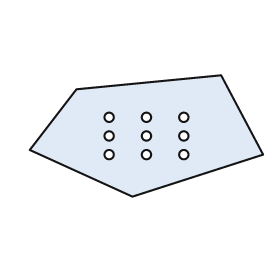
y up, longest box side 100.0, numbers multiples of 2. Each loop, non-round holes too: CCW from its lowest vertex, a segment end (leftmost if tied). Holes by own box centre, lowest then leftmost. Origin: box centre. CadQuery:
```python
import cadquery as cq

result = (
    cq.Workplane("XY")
    .moveTo(-6.0, -26.0)
    .lineTo(50.0, -8.0)
    .lineTo(32.0, 26.0)
    .lineTo(-30.0, 20.0)
    .lineTo(-50.0, -6.0)
    .close()
    .moveTo(-16.0, -8.0)
    .circle(2.0)
    .moveTo(0.0, -8.0)
    .circle(2.0)
    .moveTo(16.0, -8.0)
    .circle(2.0)
    .moveTo(-16.0, 0.0)
    .circle(2.0)
    .moveTo(0.0, 0.0)
    .circle(2.0)
    .moveTo(16.0, 0.0)
    .circle(2.0)
    .moveTo(-16.0, 8.0)
    .circle(2.0)
    .moveTo(0.0, 8.0)
    .circle(2.0)
    .moveTo(16.0, 8.0)
    .circle(2.0)
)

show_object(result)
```